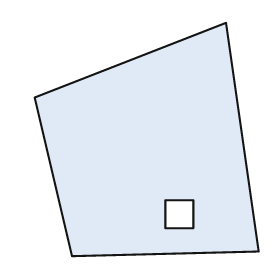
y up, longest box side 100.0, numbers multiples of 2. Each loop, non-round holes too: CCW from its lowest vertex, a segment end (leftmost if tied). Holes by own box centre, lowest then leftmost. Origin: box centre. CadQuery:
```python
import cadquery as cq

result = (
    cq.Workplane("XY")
    .moveTo(-32.0, -50.0)
    .lineTo(48.0, -48.0)
    .lineTo(34.0, 50.0)
    .lineTo(-48.0, 18.0)
    .close()
    .moveTo(8.0, -38.0)
    .lineTo(20.0, -38.0)
    .lineTo(20.0, -26.0)
    .lineTo(8.0, -26.0)
    .close()
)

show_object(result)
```